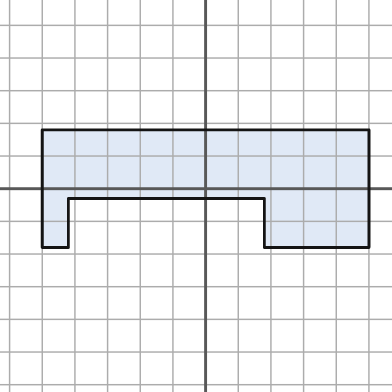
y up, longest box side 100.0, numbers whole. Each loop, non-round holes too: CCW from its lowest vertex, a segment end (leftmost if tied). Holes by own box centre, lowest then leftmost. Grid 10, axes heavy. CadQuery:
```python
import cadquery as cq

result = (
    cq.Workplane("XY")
    .moveTo(-50.0, -18.0)
    .lineTo(-42.0, -18.0)
    .lineTo(-42.0, -3.0)
    .lineTo(18.0, -3.0)
    .lineTo(18.0, -18.0)
    .lineTo(50.0, -18.0)
    .lineTo(50.0, 18.0)
    .lineTo(-50.0, 18.0)
    .close()
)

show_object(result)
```